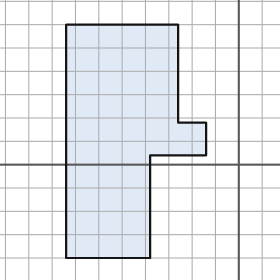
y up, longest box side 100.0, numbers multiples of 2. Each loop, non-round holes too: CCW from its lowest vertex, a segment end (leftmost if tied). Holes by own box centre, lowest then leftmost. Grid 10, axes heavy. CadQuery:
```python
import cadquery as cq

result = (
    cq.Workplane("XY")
    .moveTo(-74.0, -40.0)
    .lineTo(-38.0, -40.0)
    .lineTo(-38.0, 4.0)
    .lineTo(-14.0, 4.0)
    .lineTo(-14.0, 18.0)
    .lineTo(-26.0, 18.0)
    .lineTo(-26.0, 60.0)
    .lineTo(-74.0, 60.0)
    .close()
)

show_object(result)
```